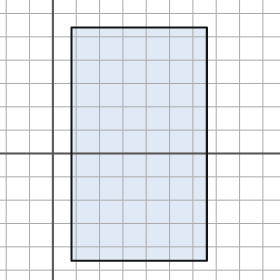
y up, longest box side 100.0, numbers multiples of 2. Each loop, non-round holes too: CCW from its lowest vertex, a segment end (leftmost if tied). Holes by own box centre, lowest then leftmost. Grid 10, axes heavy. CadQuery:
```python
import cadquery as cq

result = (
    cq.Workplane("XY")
    .moveTo(8.0, -46.0)
    .lineTo(66.0, -46.0)
    .lineTo(66.0, 54.0)
    .lineTo(8.0, 54.0)
    .close()
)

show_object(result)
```